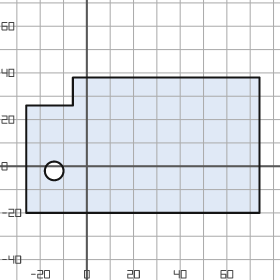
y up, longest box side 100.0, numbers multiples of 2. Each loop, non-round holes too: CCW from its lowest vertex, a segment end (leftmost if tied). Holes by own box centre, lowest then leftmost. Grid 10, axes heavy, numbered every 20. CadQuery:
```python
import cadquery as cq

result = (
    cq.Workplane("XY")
    .moveTo(-26.0, -20.0)
    .lineTo(74.0, -20.0)
    .lineTo(74.0, 38.0)
    .lineTo(-6.0, 38.0)
    .lineTo(-6.0, 26.0)
    .lineTo(-26.0, 26.0)
    .close()
    .moveTo(-14.0, -2.0)
    .circle(4.0)
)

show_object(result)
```